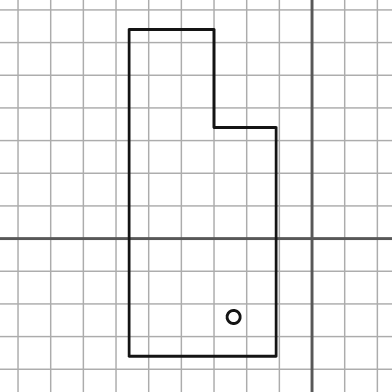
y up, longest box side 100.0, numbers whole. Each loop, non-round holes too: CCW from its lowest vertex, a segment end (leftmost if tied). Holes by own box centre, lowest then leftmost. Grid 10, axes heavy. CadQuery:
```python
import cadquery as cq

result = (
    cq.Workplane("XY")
    .moveTo(-56.0, -36.0)
    .lineTo(-11.0, -36.0)
    .lineTo(-11.0, 34.0)
    .lineTo(-30.0, 34.0)
    .lineTo(-30.0, 64.0)
    .lineTo(-56.0, 64.0)
    .close()
    .moveTo(-24.0, -24.0)
    .circle(2.0)
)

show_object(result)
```